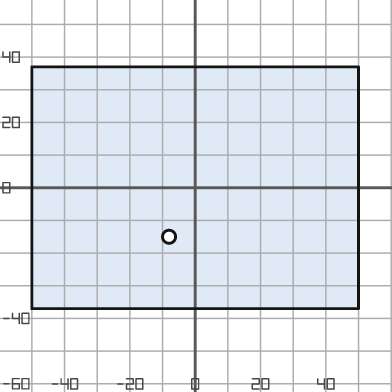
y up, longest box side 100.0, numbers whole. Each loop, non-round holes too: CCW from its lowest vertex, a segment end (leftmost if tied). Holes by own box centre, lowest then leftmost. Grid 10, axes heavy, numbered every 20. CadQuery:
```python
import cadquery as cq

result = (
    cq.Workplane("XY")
    .moveTo(-50.0, -37.0)
    .lineTo(50.0, -37.0)
    .lineTo(50.0, 37.0)
    .lineTo(-50.0, 37.0)
    .close()
    .moveTo(-8.0, -15.0)
    .circle(2.0)
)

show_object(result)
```